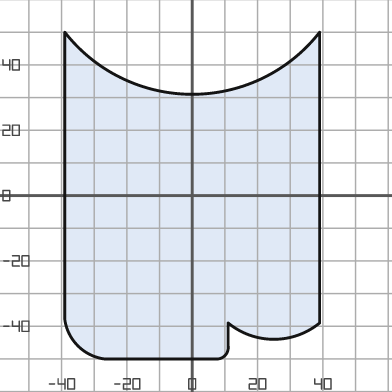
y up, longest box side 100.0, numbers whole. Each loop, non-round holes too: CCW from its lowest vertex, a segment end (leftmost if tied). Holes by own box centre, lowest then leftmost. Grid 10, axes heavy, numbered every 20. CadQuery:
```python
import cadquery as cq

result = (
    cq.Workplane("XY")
    .moveTo(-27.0, -50.0)
    .lineTo(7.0, -50.0)
    .threePointArc((10.0, -49.0), (11.0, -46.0))
    .lineTo(11.0, -39.0)
    .threePointArc((25.0, -44.0), (39.0, -39.0))
    .lineTo(39.0, 50.0)
    .threePointArc((0.0, 31.0), (-39.0, 50.0))
    .lineTo(-39.0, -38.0)
    .threePointArc((-35.0, -46.0), (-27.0, -50.0))
    .close()
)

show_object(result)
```